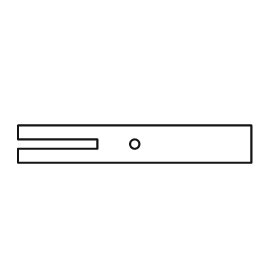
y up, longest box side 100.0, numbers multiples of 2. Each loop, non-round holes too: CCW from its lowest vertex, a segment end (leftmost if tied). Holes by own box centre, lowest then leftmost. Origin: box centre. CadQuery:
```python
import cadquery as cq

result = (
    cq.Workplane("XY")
    .moveTo(-50.0, -8.0)
    .lineTo(50.0, -8.0)
    .lineTo(50.0, 8.0)
    .lineTo(-50.0, 8.0)
    .lineTo(-50.0, 2.0)
    .lineTo(-16.0, 2.0)
    .lineTo(-16.0, -2.0)
    .lineTo(-50.0, -2.0)
    .close()
    .moveTo(0.0, 0.0)
    .circle(2.0)
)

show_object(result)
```